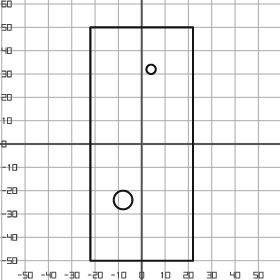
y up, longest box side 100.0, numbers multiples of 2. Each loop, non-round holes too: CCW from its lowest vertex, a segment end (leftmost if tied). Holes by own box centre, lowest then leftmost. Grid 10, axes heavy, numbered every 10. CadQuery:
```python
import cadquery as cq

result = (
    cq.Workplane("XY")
    .moveTo(-22.0, -50.0)
    .lineTo(22.0, -50.0)
    .lineTo(22.0, 50.0)
    .lineTo(-22.0, 50.0)
    .close()
    .moveTo(-8.0, -24.0)
    .circle(4.0)
    .moveTo(4.0, 32.0)
    .circle(2.0)
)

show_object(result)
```